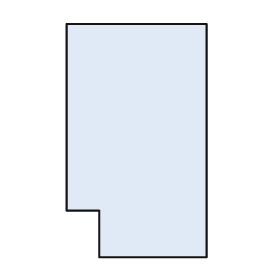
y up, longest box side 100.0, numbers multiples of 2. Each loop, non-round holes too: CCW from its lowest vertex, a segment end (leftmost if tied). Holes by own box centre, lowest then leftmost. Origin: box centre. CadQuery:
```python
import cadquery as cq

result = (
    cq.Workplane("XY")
    .moveTo(-16.0, -50.0)
    .lineTo(30.0, -50.0)
    .lineTo(30.0, 50.0)
    .lineTo(-30.0, 50.0)
    .lineTo(-30.0, -30.0)
    .lineTo(-16.0, -30.0)
    .close()
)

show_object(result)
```